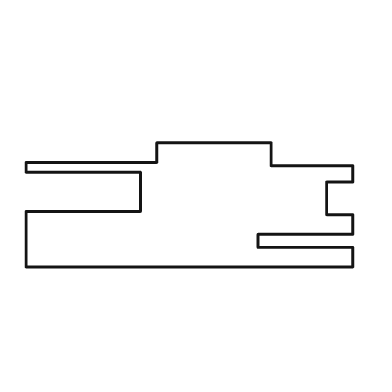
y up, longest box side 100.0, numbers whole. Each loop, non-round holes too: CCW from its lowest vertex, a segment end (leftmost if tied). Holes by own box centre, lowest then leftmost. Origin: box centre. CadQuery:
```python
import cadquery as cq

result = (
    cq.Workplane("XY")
    .moveTo(-50.0, -19.0)
    .lineTo(50.0, -19.0)
    .lineTo(50.0, -13.0)
    .lineTo(21.0, -13.0)
    .lineTo(21.0, -9.0)
    .lineTo(50.0, -9.0)
    .lineTo(50.0, -3.0)
    .lineTo(42.0, -3.0)
    .lineTo(42.0, 7.0)
    .lineTo(50.0, 7.0)
    .lineTo(50.0, 12.0)
    .lineTo(25.0, 12.0)
    .lineTo(25.0, 19.0)
    .lineTo(-10.0, 19.0)
    .lineTo(-10.0, 13.0)
    .lineTo(-50.0, 13.0)
    .lineTo(-50.0, 10.0)
    .lineTo(-15.0, 10.0)
    .lineTo(-15.0, -2.0)
    .lineTo(-50.0, -2.0)
    .close()
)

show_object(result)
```